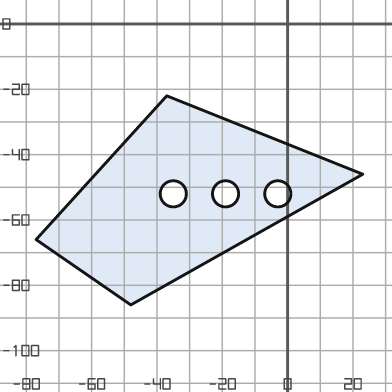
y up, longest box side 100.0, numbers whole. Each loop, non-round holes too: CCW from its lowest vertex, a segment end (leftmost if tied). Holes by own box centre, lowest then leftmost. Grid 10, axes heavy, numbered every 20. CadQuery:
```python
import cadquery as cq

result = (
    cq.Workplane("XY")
    .moveTo(-48.0, -86.0)
    .lineTo(23.0, -46.0)
    .lineTo(-37.0, -22.0)
    .lineTo(-77.0, -66.0)
    .close()
    .moveTo(-35.0, -52.0)
    .circle(4.0)
    .moveTo(-19.0, -52.0)
    .circle(4.0)
    .moveTo(-3.0, -52.0)
    .circle(4.0)
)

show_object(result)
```